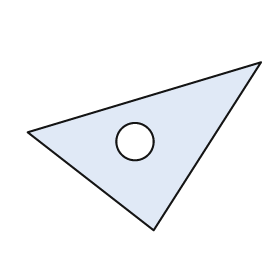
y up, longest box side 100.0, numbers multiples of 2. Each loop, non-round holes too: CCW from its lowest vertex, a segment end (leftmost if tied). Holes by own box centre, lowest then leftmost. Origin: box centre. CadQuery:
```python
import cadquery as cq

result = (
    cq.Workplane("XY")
    .moveTo(4.0, -36.0)
    .lineTo(50.0, 36.0)
    .lineTo(-50.0, 6.0)
    .close()
    .moveTo(-4.0, 2.0)
    .circle(8.0)
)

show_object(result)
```